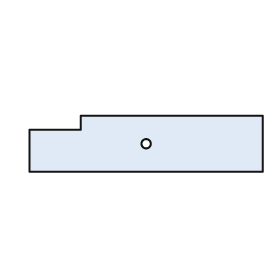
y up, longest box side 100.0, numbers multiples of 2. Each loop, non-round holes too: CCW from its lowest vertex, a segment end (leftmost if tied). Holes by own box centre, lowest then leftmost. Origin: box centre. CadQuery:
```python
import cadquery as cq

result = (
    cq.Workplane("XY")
    .moveTo(-50.0, -12.0)
    .lineTo(50.0, -12.0)
    .lineTo(50.0, 12.0)
    .lineTo(-28.0, 12.0)
    .lineTo(-28.0, 6.0)
    .lineTo(-50.0, 6.0)
    .close()
    .moveTo(0.0, 0.0)
    .circle(2.0)
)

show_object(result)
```